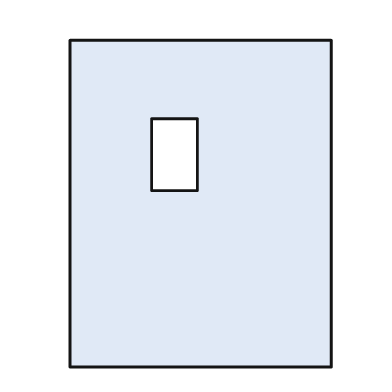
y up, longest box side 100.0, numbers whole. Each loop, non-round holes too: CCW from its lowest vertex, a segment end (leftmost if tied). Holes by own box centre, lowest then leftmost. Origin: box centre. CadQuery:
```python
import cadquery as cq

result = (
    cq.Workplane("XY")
    .moveTo(-40.0, -50.0)
    .lineTo(40.0, -50.0)
    .lineTo(40.0, 50.0)
    .lineTo(-40.0, 50.0)
    .close()
    .moveTo(-15.0, 4.0)
    .lineTo(-1.0, 4.0)
    .lineTo(-1.0, 26.0)
    .lineTo(-15.0, 26.0)
    .close()
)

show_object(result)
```